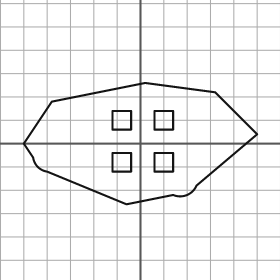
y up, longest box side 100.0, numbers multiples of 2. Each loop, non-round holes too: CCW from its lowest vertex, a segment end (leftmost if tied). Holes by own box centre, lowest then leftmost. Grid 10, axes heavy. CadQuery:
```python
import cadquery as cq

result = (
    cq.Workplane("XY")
    .moveTo(-6.0, -26.0)
    .lineTo(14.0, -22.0)
    .threePointArc((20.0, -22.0), (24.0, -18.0))
    .lineTo(50.0, 4.0)
    .lineTo(32.0, 22.0)
    .lineTo(2.0, 26.0)
    .lineTo(-38.0, 18.0)
    .lineTo(-50.0, 0.0)
    .lineTo(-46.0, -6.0)
    .threePointArc((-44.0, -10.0), (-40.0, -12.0))
    .close()
    .moveTo(-12.0, -12.0)
    .lineTo(-4.0, -12.0)
    .lineTo(-4.0, -4.0)
    .lineTo(-12.0, -4.0)
    .close()
    .moveTo(6.0, -12.0)
    .lineTo(14.0, -12.0)
    .lineTo(14.0, -4.0)
    .lineTo(6.0, -4.0)
    .close()
    .moveTo(-12.0, 6.0)
    .lineTo(-4.0, 6.0)
    .lineTo(-4.0, 14.0)
    .lineTo(-12.0, 14.0)
    .close()
    .moveTo(6.0, 6.0)
    .lineTo(14.0, 6.0)
    .lineTo(14.0, 14.0)
    .lineTo(6.0, 14.0)
    .close()
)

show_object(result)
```